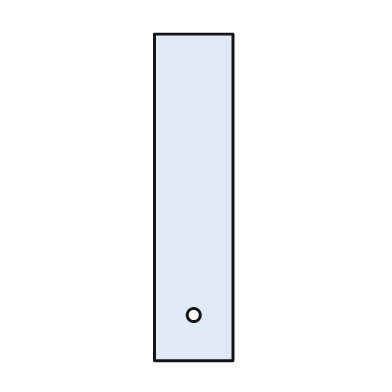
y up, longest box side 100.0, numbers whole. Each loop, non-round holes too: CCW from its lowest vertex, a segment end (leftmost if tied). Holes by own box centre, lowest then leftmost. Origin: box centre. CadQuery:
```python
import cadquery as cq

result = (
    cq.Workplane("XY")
    .moveTo(-12.0, -50.0)
    .lineTo(12.0, -50.0)
    .lineTo(12.0, 50.0)
    .lineTo(-12.0, 50.0)
    .close()
    .moveTo(0.0, -36.0)
    .circle(2.0)
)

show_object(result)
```